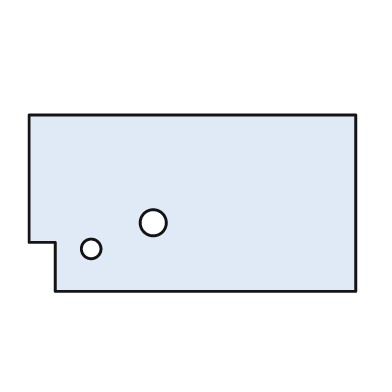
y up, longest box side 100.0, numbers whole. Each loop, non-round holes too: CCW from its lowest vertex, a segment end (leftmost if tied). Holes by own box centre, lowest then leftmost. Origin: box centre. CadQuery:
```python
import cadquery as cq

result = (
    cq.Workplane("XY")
    .moveTo(-42.0, -27.0)
    .lineTo(50.0, -27.0)
    .lineTo(50.0, 27.0)
    .lineTo(-50.0, 27.0)
    .lineTo(-50.0, -12.0)
    .lineTo(-42.0, -12.0)
    .close()
    .moveTo(-31.0, -14.0)
    .circle(3.0)
    .moveTo(-12.0, -6.0)
    .circle(4.0)
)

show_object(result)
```